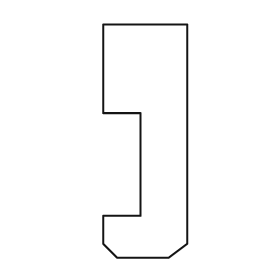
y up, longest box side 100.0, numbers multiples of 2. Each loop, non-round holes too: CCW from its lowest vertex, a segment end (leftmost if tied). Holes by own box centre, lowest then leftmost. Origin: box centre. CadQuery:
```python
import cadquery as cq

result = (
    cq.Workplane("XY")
    .moveTo(-12.0, -50.0)
    .lineTo(10.0, -50.0)
    .lineTo(18.0, -44.0)
    .lineTo(18.0, 50.0)
    .lineTo(-18.0, 50.0)
    .lineTo(-18.0, 12.0)
    .lineTo(-2.0, 12.0)
    .lineTo(-2.0, -32.0)
    .lineTo(-18.0, -32.0)
    .lineTo(-18.0, -44.0)
    .close()
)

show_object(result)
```